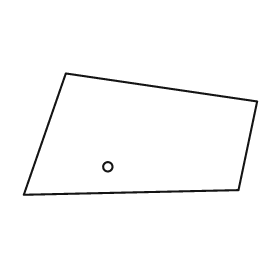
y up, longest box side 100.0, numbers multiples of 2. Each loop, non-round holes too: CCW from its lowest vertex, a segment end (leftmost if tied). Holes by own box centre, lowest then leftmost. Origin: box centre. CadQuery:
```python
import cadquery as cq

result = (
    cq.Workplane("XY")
    .moveTo(-50.0, -26.0)
    .lineTo(42.0, -24.0)
    .lineTo(50.0, 14.0)
    .lineTo(-32.0, 26.0)
    .close()
    .moveTo(-14.0, -14.0)
    .circle(2.0)
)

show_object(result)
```